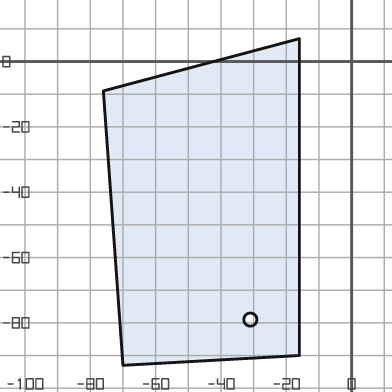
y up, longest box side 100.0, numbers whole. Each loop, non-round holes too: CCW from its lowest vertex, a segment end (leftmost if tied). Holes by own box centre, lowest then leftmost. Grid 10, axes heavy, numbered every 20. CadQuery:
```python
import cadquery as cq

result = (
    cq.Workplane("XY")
    .moveTo(-70.0, -93.0)
    .lineTo(-16.0, -90.0)
    .lineTo(-16.0, 7.0)
    .lineTo(-76.0, -9.0)
    .close()
    .moveTo(-31.0, -79.0)
    .circle(2.0)
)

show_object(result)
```